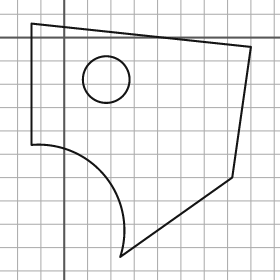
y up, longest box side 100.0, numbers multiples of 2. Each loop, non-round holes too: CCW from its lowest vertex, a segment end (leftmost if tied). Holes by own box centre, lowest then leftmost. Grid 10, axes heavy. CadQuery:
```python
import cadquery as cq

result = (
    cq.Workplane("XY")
    .moveTo(24.0, -94.0)
    .lineTo(72.0, -60.0)
    .lineTo(80.0, -4.0)
    .lineTo(-14.0, 6.0)
    .lineTo(-14.0, -46.0)
    .threePointArc((18.0, -60.0), (24.0, -94.0))
    .close()
    .moveTo(18.0, -18.0)
    .circle(10.0)
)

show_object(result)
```